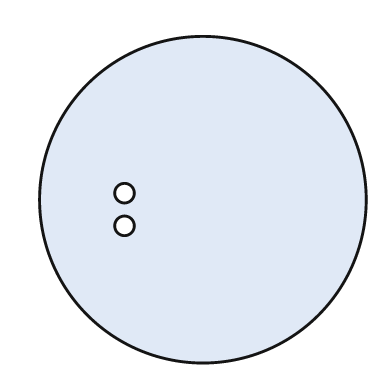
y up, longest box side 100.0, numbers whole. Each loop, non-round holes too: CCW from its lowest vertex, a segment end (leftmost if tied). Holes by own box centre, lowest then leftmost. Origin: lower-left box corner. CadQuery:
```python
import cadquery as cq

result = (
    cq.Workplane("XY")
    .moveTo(50.0, 50.0)
    .circle(50.0)
    .moveTo(26.0, 42.0)
    .circle(3.0)
    .moveTo(26.0, 52.0)
    .circle(3.0)
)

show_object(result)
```